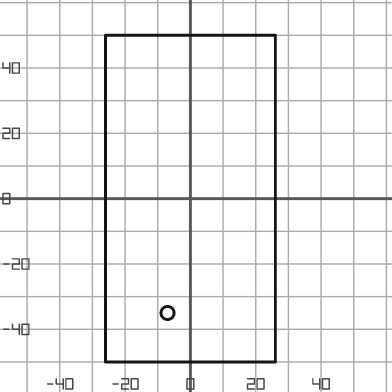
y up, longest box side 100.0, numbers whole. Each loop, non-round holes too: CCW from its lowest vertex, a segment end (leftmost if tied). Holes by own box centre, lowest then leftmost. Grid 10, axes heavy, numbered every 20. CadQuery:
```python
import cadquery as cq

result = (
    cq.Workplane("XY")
    .moveTo(-26.0, -50.0)
    .lineTo(26.0, -50.0)
    .lineTo(26.0, 50.0)
    .lineTo(-26.0, 50.0)
    .close()
    .moveTo(-7.0, -35.0)
    .circle(2.0)
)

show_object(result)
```